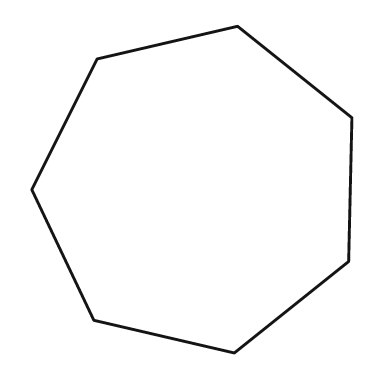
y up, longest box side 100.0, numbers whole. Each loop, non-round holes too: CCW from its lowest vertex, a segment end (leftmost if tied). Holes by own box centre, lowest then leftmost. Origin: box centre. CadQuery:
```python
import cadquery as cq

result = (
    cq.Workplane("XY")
    .moveTo(13.0, -50.0)
    .lineTo(48.0, -22.0)
    .lineTo(49.0, 22.0)
    .lineTo(14.0, 50.0)
    .lineTo(-29.0, 40.0)
    .lineTo(-49.0, 0.0)
    .lineTo(-30.0, -40.0)
    .close()
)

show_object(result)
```